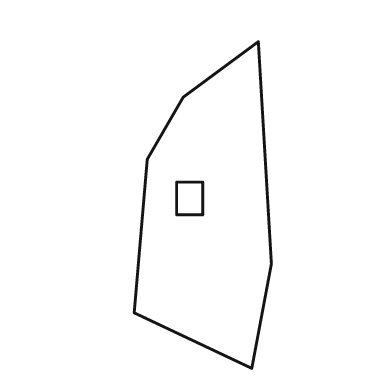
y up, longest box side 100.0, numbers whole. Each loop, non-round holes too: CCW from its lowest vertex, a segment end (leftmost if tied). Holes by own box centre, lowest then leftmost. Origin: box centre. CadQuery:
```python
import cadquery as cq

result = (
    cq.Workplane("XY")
    .moveTo(15.0, -50.0)
    .lineTo(21.0, -18.0)
    .lineTo(17.0, 50.0)
    .lineTo(-6.0, 33.0)
    .lineTo(-17.0, 14.0)
    .lineTo(-21.0, -33.0)
    .close()
    .moveTo(-8.0, -3.0)
    .lineTo(0.0, -3.0)
    .lineTo(0.0, 7.0)
    .lineTo(-8.0, 7.0)
    .close()
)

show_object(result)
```